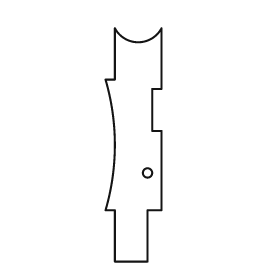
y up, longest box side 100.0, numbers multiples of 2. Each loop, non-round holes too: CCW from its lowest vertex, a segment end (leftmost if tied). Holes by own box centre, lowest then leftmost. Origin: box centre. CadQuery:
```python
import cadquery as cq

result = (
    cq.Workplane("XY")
    .moveTo(-8.0, -50.0)
    .lineTo(6.0, -50.0)
    .lineTo(6.0, -28.0)
    .lineTo(12.0, -28.0)
    .lineTo(12.0, 6.0)
    .lineTo(8.0, 6.0)
    .lineTo(8.0, 24.0)
    .lineTo(12.0, 24.0)
    .lineTo(12.0, 50.0)
    .threePointArc((2.0, 44.0), (-8.0, 50.0))
    .lineTo(-8.0, 28.0)
    .lineTo(-12.0, 28.0)
    .threePointArc((-8.0, 0.0), (-12.0, -28.0))
    .lineTo(-8.0, -28.0)
    .close()
    .moveTo(6.0, -12.0)
    .circle(2.0)
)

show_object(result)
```